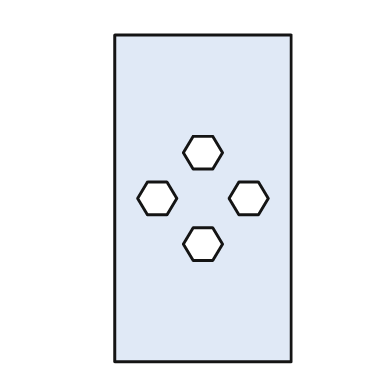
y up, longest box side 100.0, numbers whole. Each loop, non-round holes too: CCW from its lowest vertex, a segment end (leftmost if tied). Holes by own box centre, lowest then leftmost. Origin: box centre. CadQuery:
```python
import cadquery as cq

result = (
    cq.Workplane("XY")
    .moveTo(-27.0, -50.0)
    .lineTo(27.0, -50.0)
    .lineTo(27.0, 50.0)
    .lineTo(-27.0, 50.0)
    .close()
    .moveTo(-3.0, -19.0)
    .lineTo(3.0, -19.0)
    .lineTo(6.0, -14.0)
    .lineTo(3.0, -9.0)
    .lineTo(-3.0, -9.0)
    .lineTo(-6.0, -14.0)
    .close()
    .moveTo(-17.0, -5.0)
    .lineTo(-11.0, -5.0)
    .lineTo(-8.0, 0.0)
    .lineTo(-11.0, 5.0)
    .lineTo(-17.0, 5.0)
    .lineTo(-20.0, 0.0)
    .close()
    .moveTo(11.0, -5.0)
    .lineTo(17.0, -5.0)
    .lineTo(20.0, 0.0)
    .lineTo(17.0, 5.0)
    .lineTo(11.0, 5.0)
    .lineTo(8.0, 0.0)
    .close()
    .moveTo(-3.0, 9.0)
    .lineTo(3.0, 9.0)
    .lineTo(6.0, 14.0)
    .lineTo(3.0, 19.0)
    .lineTo(-3.0, 19.0)
    .lineTo(-6.0, 14.0)
    .close()
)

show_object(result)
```